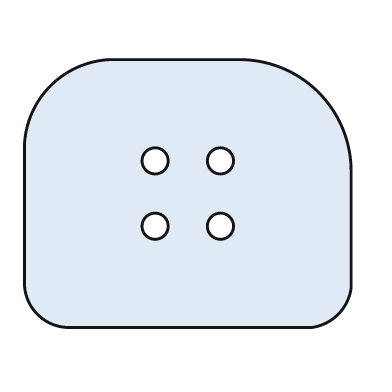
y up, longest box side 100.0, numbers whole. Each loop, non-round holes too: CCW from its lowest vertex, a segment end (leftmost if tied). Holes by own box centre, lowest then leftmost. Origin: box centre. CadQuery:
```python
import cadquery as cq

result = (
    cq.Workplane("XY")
    .moveTo(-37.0, -41.0)
    .lineTo(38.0, -41.0)
    .threePointArc((46.0, -37.0), (50.0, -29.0))
    .lineTo(50.0, 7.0)
    .threePointArc((40.0, 31.0), (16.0, 41.0))
    .lineTo(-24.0, 41.0)
    .threePointArc((-42.0, 33.0), (-50.0, 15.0))
    .lineTo(-50.0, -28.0)
    .threePointArc((-46.0, -37.0), (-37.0, -41.0))
    .close()
    .moveTo(-10.0, -10.0)
    .circle(4.0)
    .moveTo(10.0, -10.0)
    .circle(4.0)
    .moveTo(-10.0, 10.0)
    .circle(4.0)
    .moveTo(10.0, 10.0)
    .circle(4.0)
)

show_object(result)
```